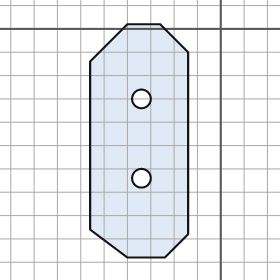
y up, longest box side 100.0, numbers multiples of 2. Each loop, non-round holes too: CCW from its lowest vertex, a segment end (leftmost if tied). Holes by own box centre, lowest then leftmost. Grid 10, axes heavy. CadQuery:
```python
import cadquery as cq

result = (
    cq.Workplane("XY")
    .moveTo(-40.0, -98.0)
    .lineTo(-24.0, -98.0)
    .lineTo(-14.0, -88.0)
    .lineTo(-14.0, -10.0)
    .lineTo(-26.0, 2.0)
    .lineTo(-40.0, 2.0)
    .lineTo(-56.0, -14.0)
    .lineTo(-56.0, -86.0)
    .close()
    .moveTo(-34.0, -64.0)
    .circle(4.0)
    .moveTo(-34.0, -30.0)
    .circle(4.0)
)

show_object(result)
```